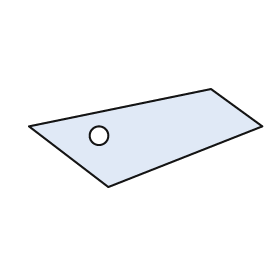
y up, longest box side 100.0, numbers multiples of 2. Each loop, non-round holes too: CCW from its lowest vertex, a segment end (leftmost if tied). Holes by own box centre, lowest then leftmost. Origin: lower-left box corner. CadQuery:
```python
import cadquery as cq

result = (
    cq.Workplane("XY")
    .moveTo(34.0, 0.0)
    .lineTo(100.0, 26.0)
    .lineTo(78.0, 42.0)
    .lineTo(0.0, 26.0)
    .close()
    .moveTo(30.0, 22.0)
    .circle(4.0)
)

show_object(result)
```